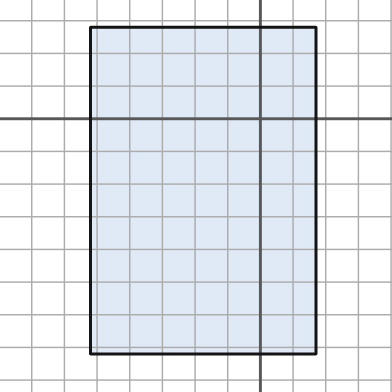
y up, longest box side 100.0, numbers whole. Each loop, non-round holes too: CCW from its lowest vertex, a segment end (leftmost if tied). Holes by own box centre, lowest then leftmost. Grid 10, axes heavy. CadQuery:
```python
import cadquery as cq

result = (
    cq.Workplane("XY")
    .moveTo(-52.0, -72.0)
    .lineTo(17.0, -72.0)
    .lineTo(17.0, 28.0)
    .lineTo(-52.0, 28.0)
    .close()
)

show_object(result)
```